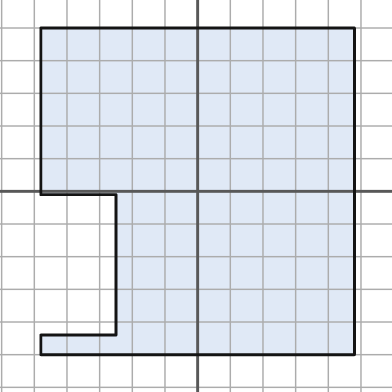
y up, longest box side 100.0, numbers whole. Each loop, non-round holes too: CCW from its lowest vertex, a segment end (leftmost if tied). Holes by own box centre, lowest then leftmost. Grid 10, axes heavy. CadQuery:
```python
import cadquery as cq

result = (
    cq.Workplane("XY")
    .moveTo(-48.0, -50.0)
    .lineTo(48.0, -50.0)
    .lineTo(48.0, 50.0)
    .lineTo(-48.0, 50.0)
    .lineTo(-48.0, -1.0)
    .lineTo(-25.0, -1.0)
    .lineTo(-25.0, -44.0)
    .lineTo(-48.0, -44.0)
    .close()
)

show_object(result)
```